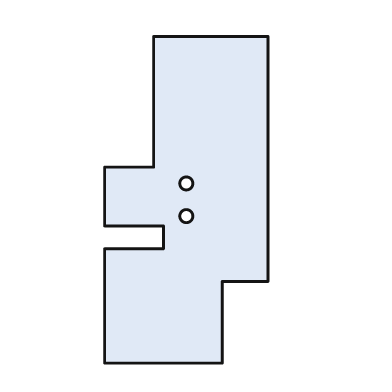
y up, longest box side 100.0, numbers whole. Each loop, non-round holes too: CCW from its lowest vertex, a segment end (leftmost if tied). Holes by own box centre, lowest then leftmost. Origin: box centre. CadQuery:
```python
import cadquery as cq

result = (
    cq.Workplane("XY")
    .moveTo(-25.0, -50.0)
    .lineTo(11.0, -50.0)
    .lineTo(11.0, -25.0)
    .lineTo(25.0, -25.0)
    .lineTo(25.0, 50.0)
    .lineTo(-10.0, 50.0)
    .lineTo(-10.0, 10.0)
    .lineTo(-25.0, 10.0)
    .lineTo(-25.0, -8.0)
    .lineTo(-7.0, -8.0)
    .lineTo(-7.0, -15.0)
    .lineTo(-25.0, -15.0)
    .close()
    .moveTo(0.0, -5.0)
    .circle(2.0)
    .moveTo(0.0, 5.0)
    .circle(2.0)
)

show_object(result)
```